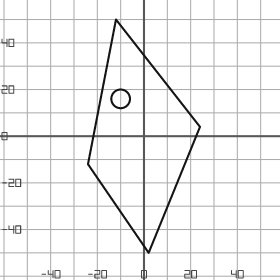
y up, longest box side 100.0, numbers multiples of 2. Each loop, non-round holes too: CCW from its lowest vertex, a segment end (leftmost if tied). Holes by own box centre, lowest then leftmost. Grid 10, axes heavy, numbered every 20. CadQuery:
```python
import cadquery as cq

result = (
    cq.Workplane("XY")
    .moveTo(2.0, -50.0)
    .lineTo(24.0, 4.0)
    .lineTo(-12.0, 50.0)
    .lineTo(-24.0, -12.0)
    .close()
    .moveTo(-10.0, 16.0)
    .circle(4.0)
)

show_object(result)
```